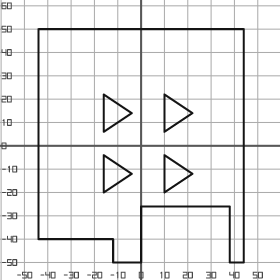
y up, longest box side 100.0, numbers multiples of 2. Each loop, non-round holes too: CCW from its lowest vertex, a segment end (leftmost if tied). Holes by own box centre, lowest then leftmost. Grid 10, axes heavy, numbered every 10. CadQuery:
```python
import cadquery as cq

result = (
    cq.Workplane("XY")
    .moveTo(-12.0, -50.0)
    .lineTo(0.0, -50.0)
    .lineTo(0.0, -26.0)
    .lineTo(38.0, -26.0)
    .lineTo(38.0, -50.0)
    .lineTo(44.0, -50.0)
    .lineTo(44.0, 50.0)
    .lineTo(-44.0, 50.0)
    .lineTo(-44.0, -40.0)
    .lineTo(-12.0, -40.0)
    .close()
    .moveTo(-16.0, -20.0)
    .lineTo(-4.0, -12.0)
    .lineTo(-16.0, -4.0)
    .close()
    .moveTo(10.0, -20.0)
    .lineTo(22.0, -12.0)
    .lineTo(10.0, -4.0)
    .close()
    .moveTo(-16.0, 6.0)
    .lineTo(-4.0, 14.0)
    .lineTo(-16.0, 22.0)
    .close()
    .moveTo(10.0, 6.0)
    .lineTo(22.0, 14.0)
    .lineTo(10.0, 22.0)
    .close()
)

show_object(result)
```